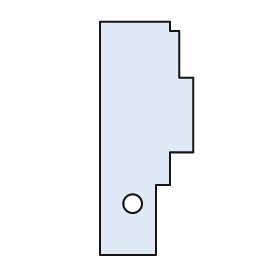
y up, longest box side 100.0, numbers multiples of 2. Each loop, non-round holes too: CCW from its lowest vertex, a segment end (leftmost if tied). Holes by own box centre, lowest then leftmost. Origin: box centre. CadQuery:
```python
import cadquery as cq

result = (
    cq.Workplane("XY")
    .moveTo(-20.0, -50.0)
    .lineTo(4.0, -50.0)
    .lineTo(4.0, -20.0)
    .lineTo(10.0, -20.0)
    .lineTo(10.0, -6.0)
    .lineTo(20.0, -6.0)
    .lineTo(20.0, 26.0)
    .lineTo(14.0, 26.0)
    .lineTo(14.0, 46.0)
    .lineTo(10.0, 46.0)
    .lineTo(10.0, 50.0)
    .lineTo(-20.0, 50.0)
    .close()
    .moveTo(-6.0, -28.0)
    .circle(4.0)
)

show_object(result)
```